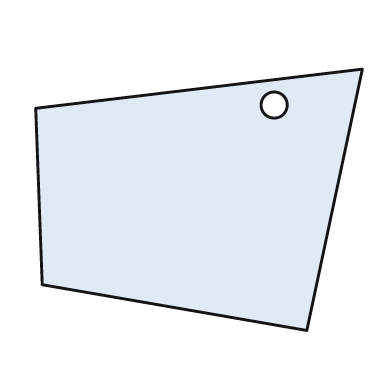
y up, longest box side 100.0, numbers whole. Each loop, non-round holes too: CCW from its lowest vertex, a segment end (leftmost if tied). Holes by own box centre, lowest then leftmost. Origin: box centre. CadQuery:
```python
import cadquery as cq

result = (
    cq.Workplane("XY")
    .moveTo(33.0, -40.0)
    .lineTo(50.0, 40.0)
    .lineTo(-50.0, 28.0)
    .lineTo(-48.0, -26.0)
    .close()
    .moveTo(23.0, 29.0)
    .circle(4.0)
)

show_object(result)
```